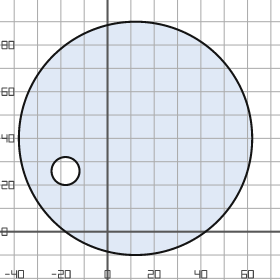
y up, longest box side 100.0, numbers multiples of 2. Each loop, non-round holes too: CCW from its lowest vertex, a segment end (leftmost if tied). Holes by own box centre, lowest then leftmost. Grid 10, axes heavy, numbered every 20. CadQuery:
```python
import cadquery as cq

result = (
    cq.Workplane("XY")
    .moveTo(12.0, 40.0)
    .circle(50.0)
    .moveTo(-18.0, 26.0)
    .circle(6.0)
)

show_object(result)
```